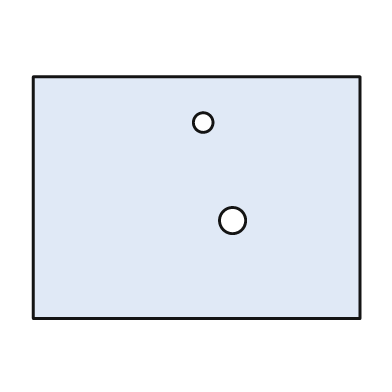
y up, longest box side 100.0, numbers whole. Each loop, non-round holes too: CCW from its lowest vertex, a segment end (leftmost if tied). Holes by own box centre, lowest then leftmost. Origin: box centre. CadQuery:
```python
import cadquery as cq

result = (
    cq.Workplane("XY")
    .moveTo(-50.0, -37.0)
    .lineTo(50.0, -37.0)
    .lineTo(50.0, 37.0)
    .lineTo(-50.0, 37.0)
    .close()
    .moveTo(11.0, -7.0)
    .circle(4.0)
    .moveTo(2.0, 23.0)
    .circle(3.0)
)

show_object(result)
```